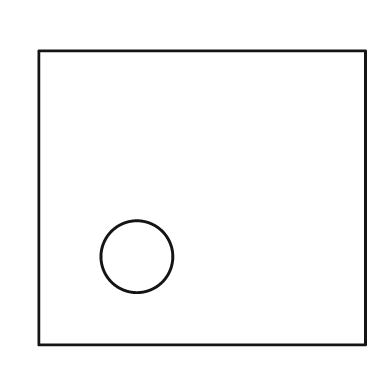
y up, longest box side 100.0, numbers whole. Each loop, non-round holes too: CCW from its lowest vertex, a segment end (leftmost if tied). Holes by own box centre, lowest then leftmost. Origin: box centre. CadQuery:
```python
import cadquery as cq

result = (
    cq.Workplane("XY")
    .moveTo(-50.0, -45.0)
    .lineTo(50.0, -45.0)
    .lineTo(50.0, 45.0)
    .lineTo(-50.0, 45.0)
    .close()
    .moveTo(-20.0, -18.0)
    .circle(11.0)
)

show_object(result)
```